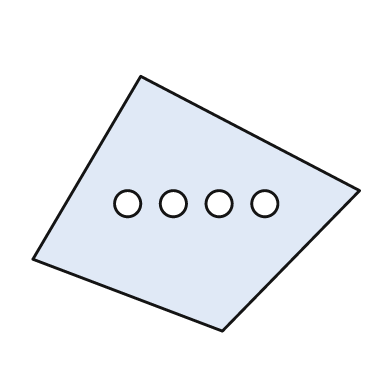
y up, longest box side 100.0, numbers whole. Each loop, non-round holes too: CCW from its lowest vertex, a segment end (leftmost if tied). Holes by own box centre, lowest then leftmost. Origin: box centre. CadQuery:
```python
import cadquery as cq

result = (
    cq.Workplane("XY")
    .moveTo(8.0, -39.0)
    .lineTo(50.0, 4.0)
    .lineTo(-17.0, 39.0)
    .lineTo(-50.0, -17.0)
    .close()
    .moveTo(-21.0, 0.0)
    .circle(4.0)
    .moveTo(-7.0, 0.0)
    .circle(4.0)
    .moveTo(7.0, 0.0)
    .circle(4.0)
    .moveTo(21.0, 0.0)
    .circle(4.0)
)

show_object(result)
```